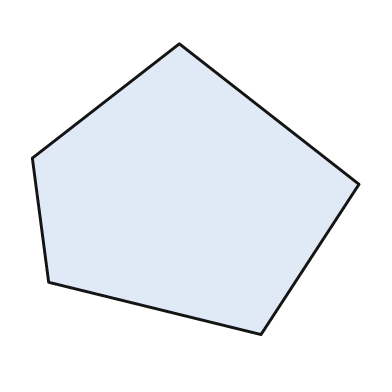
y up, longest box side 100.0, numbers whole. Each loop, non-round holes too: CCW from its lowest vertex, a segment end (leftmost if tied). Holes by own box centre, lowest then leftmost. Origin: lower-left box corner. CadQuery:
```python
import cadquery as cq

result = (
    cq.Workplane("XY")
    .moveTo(70.0, 0.0)
    .lineTo(100.0, 46.0)
    .lineTo(45.0, 89.0)
    .lineTo(0.0, 54.0)
    .lineTo(5.0, 16.0)
    .close()
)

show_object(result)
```